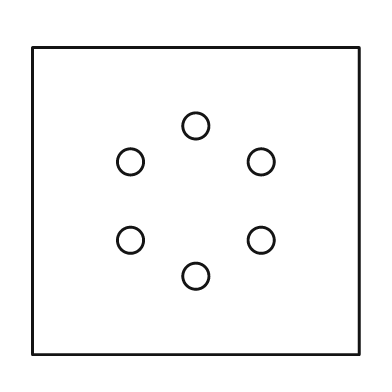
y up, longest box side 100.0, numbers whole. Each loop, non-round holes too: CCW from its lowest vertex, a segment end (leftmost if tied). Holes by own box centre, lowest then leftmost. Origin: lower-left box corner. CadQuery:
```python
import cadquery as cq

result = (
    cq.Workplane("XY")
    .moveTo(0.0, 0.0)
    .lineTo(100.0, 0.0)
    .lineTo(100.0, 94.0)
    .lineTo(0.0, 94.0)
    .close()
    .moveTo(50.0, 24.0)
    .circle(4.0)
    .moveTo(30.0, 35.0)
    .circle(4.0)
    .moveTo(70.0, 35.0)
    .circle(4.0)
    .moveTo(30.0, 59.0)
    .circle(4.0)
    .moveTo(70.0, 59.0)
    .circle(4.0)
    .moveTo(50.0, 70.0)
    .circle(4.0)
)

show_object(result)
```